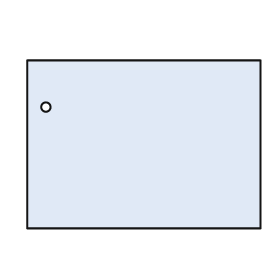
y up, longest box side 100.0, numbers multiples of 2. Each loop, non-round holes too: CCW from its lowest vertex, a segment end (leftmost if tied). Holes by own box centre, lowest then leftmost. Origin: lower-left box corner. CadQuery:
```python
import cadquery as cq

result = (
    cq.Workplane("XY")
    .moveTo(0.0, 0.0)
    .lineTo(100.0, 0.0)
    .lineTo(100.0, 72.0)
    .lineTo(0.0, 72.0)
    .close()
    .moveTo(8.0, 52.0)
    .circle(2.0)
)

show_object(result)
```